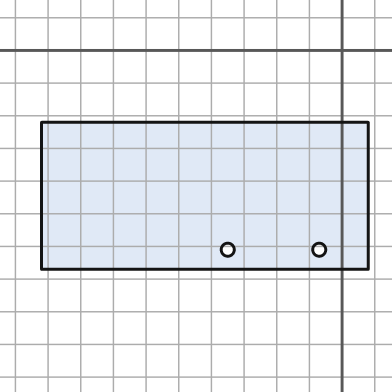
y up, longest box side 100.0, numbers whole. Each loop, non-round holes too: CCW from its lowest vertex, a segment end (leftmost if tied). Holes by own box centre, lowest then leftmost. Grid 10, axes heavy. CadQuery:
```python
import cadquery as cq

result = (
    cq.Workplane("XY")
    .moveTo(-92.0, -67.0)
    .lineTo(8.0, -67.0)
    .lineTo(8.0, -22.0)
    .lineTo(-92.0, -22.0)
    .close()
    .moveTo(-35.0, -61.0)
    .circle(2.0)
    .moveTo(-7.0, -61.0)
    .circle(2.0)
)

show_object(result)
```